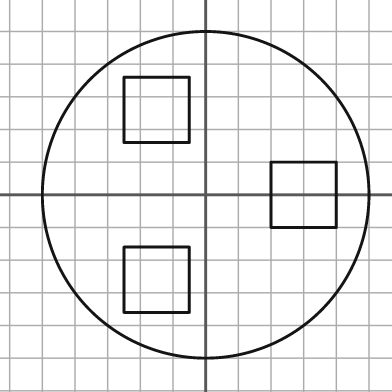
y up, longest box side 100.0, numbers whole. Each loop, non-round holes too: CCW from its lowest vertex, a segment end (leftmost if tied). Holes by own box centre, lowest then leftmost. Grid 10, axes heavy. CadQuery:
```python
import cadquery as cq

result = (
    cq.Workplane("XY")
    .moveTo(0.0, 0.0)
    .circle(50.0)
    .moveTo(-25.0, -36.0)
    .lineTo(-5.0, -36.0)
    .lineTo(-5.0, -16.0)
    .lineTo(-25.0, -16.0)
    .close()
    .moveTo(20.0, -10.0)
    .lineTo(40.0, -10.0)
    .lineTo(40.0, 10.0)
    .lineTo(20.0, 10.0)
    .close()
    .moveTo(-25.0, 16.0)
    .lineTo(-5.0, 16.0)
    .lineTo(-5.0, 36.0)
    .lineTo(-25.0, 36.0)
    .close()
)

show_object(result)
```